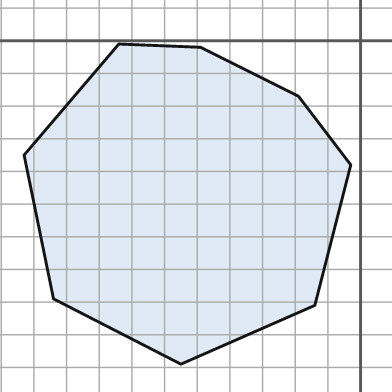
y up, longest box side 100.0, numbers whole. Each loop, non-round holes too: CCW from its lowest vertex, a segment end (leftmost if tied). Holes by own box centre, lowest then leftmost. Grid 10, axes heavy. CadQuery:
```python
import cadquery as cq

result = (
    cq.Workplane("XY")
    .moveTo(-55.0, -99.0)
    .lineTo(-14.0, -81.0)
    .lineTo(-3.0, -38.0)
    .lineTo(-19.0, -17.0)
    .lineTo(-49.0, -2.0)
    .lineTo(-74.0, -1.0)
    .lineTo(-103.0, -35.0)
    .lineTo(-94.0, -79.0)
    .close()
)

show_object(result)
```